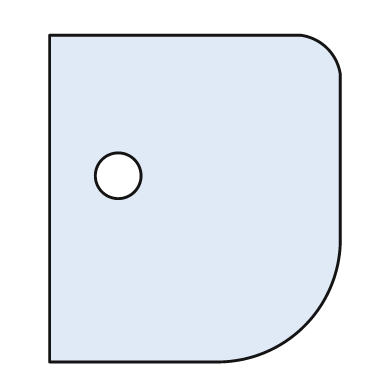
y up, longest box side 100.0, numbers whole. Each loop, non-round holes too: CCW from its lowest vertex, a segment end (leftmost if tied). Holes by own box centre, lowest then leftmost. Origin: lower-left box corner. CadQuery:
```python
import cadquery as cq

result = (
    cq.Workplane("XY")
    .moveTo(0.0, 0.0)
    .lineTo(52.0, 0.0)
    .threePointArc((78.0, 11.0), (89.0, 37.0))
    .lineTo(89.0, 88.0)
    .threePointArc((85.0, 96.0), (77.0, 100.0))
    .lineTo(0.0, 100.0)
    .close()
    .moveTo(21.0, 57.0)
    .circle(7.0)
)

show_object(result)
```